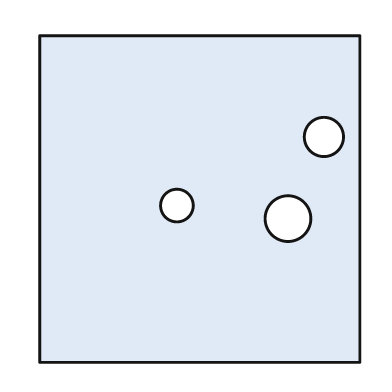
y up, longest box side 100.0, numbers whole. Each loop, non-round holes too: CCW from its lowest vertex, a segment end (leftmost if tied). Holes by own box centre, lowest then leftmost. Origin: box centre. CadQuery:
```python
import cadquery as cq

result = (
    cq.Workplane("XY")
    .moveTo(-49.0, -50.0)
    .lineTo(49.0, -50.0)
    .lineTo(49.0, 50.0)
    .lineTo(-49.0, 50.0)
    .close()
    .moveTo(27.0, -6.0)
    .circle(7.0)
    .moveTo(-7.0, -2.0)
    .circle(5.0)
    .moveTo(38.0, 19.0)
    .circle(6.0)
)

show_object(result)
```